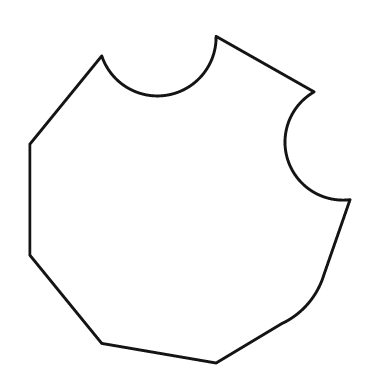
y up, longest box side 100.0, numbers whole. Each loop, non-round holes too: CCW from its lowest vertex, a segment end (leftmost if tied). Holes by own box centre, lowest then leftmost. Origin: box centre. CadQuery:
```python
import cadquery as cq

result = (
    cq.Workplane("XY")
    .moveTo(8.0, -50.0)
    .lineTo(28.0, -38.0)
    .threePointArc((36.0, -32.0), (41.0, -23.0))
    .lineTo(49.0, 0.0)
    .threePointArc((30.0, 12.0), (38.0, 33.0))
    .lineTo(8.0, 50.0)
    .threePointArc((-7.0, 32.0), (-27.0, 44.0))
    .lineTo(-49.0, 17.0)
    .lineTo(-49.0, -17.0)
    .lineTo(-27.0, -44.0)
    .close()
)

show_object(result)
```